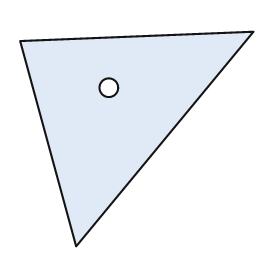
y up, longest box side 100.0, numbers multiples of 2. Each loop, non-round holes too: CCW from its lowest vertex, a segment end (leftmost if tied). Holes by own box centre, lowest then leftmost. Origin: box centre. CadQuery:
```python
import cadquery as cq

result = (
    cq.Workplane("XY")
    .moveTo(-26.0, -46.0)
    .lineTo(50.0, 46.0)
    .lineTo(-50.0, 42.0)
    .close()
    .moveTo(-12.0, 22.0)
    .circle(4.0)
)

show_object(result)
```